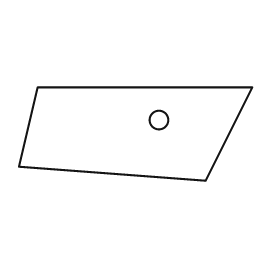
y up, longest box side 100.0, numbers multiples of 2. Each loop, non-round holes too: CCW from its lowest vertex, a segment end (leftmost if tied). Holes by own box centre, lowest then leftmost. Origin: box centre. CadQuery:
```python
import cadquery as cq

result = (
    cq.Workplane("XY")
    .moveTo(30.0, -20.0)
    .lineTo(50.0, 20.0)
    .lineTo(-42.0, 20.0)
    .lineTo(-50.0, -14.0)
    .close()
    .moveTo(10.0, 6.0)
    .circle(4.0)
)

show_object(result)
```